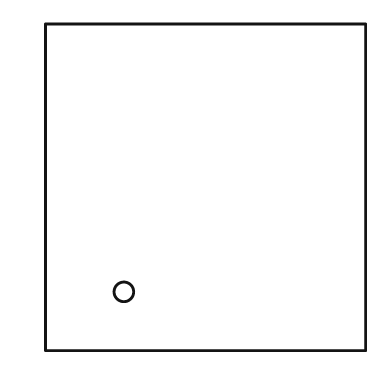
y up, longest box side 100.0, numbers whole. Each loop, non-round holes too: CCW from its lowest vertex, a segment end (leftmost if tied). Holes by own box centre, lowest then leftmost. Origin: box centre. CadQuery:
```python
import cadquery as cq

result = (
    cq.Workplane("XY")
    .moveTo(-49.0, -50.0)
    .lineTo(49.0, -50.0)
    .lineTo(49.0, 50.0)
    .lineTo(-49.0, 50.0)
    .close()
    .moveTo(-25.0, -32.0)
    .circle(3.0)
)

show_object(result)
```